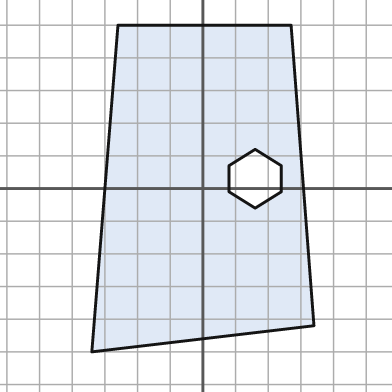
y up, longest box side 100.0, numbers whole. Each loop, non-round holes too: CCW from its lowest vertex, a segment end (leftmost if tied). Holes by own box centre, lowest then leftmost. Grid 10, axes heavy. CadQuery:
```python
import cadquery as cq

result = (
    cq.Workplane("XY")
    .moveTo(-34.0, -50.0)
    .lineTo(34.0, -42.0)
    .lineTo(27.0, 50.0)
    .lineTo(-26.0, 50.0)
    .close()
    .moveTo(16.0, -6.0)
    .lineTo(24.0, -1.0)
    .lineTo(24.0, 7.0)
    .lineTo(16.0, 12.0)
    .lineTo(8.0, 7.0)
    .lineTo(8.0, -1.0)
    .close()
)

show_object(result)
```